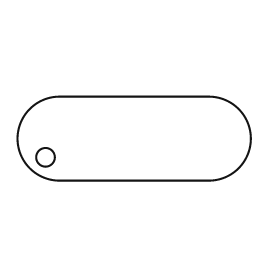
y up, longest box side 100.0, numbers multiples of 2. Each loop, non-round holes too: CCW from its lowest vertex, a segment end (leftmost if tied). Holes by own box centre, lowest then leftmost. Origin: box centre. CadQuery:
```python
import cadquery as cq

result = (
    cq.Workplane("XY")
    .moveTo(-32.0, -18.0)
    .lineTo(32.0, -18.0)
    .threePointArc((50.0, 0.0), (32.0, 18.0))
    .lineTo(-32.0, 18.0)
    .threePointArc((-50.0, 0.0), (-32.0, -18.0))
    .close()
    .moveTo(-38.0, -8.0)
    .circle(4.0)
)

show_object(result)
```